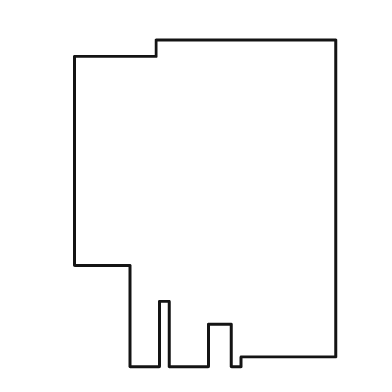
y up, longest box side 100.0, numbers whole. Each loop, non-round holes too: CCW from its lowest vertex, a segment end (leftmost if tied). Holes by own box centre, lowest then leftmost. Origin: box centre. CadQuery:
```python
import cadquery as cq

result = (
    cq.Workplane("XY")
    .moveTo(-23.0, -50.0)
    .lineTo(-14.0, -50.0)
    .lineTo(-14.0, -30.0)
    .lineTo(-11.0, -30.0)
    .lineTo(-11.0, -50.0)
    .lineTo(1.0, -50.0)
    .lineTo(1.0, -37.0)
    .lineTo(8.0, -37.0)
    .lineTo(8.0, -50.0)
    .lineTo(11.0, -50.0)
    .lineTo(11.0, -47.0)
    .lineTo(40.0, -47.0)
    .lineTo(40.0, 50.0)
    .lineTo(-15.0, 50.0)
    .lineTo(-15.0, 45.0)
    .lineTo(-40.0, 45.0)
    .lineTo(-40.0, -19.0)
    .lineTo(-23.0, -19.0)
    .close()
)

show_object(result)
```